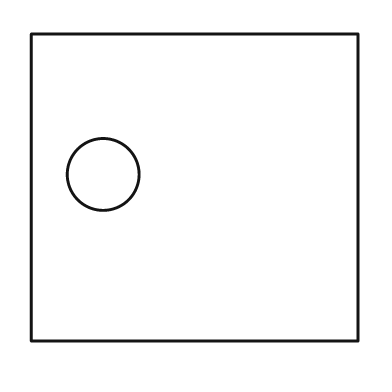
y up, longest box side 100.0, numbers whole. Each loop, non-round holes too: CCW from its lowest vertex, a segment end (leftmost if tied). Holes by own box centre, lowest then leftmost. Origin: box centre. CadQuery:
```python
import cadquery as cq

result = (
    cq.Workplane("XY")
    .moveTo(-50.0, -47.0)
    .lineTo(50.0, -47.0)
    .lineTo(50.0, 47.0)
    .lineTo(-50.0, 47.0)
    .close()
    .moveTo(-28.0, 4.0)
    .circle(11.0)
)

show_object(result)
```